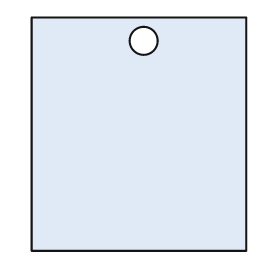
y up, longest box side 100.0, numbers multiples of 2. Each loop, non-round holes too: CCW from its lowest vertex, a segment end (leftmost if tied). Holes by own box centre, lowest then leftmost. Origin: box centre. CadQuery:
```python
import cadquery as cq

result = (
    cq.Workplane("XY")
    .moveTo(-46.0, -50.0)
    .lineTo(46.0, -50.0)
    .lineTo(46.0, 50.0)
    .lineTo(-46.0, 50.0)
    .close()
    .moveTo(2.0, 40.0)
    .circle(6.0)
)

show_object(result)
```